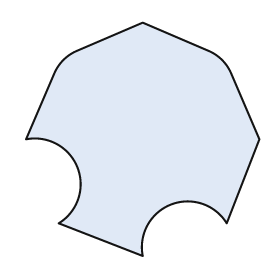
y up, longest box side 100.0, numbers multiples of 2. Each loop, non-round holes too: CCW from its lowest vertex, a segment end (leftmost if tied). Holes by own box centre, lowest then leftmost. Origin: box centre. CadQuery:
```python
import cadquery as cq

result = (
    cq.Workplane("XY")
    .moveTo(0.0, -50.0)
    .threePointArc((12.0, -28.0), (36.0, -36.0))
    .lineTo(50.0, 0.0)
    .lineTo(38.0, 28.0)
    .threePointArc((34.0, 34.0), (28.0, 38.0))
    .lineTo(0.0, 50.0)
    .lineTo(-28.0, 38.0)
    .threePointArc((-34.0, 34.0), (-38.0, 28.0))
    .lineTo(-50.0, 0.0)
    .threePointArc((-28.0, -12.0), (-36.0, -36.0))
    .close()
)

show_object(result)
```